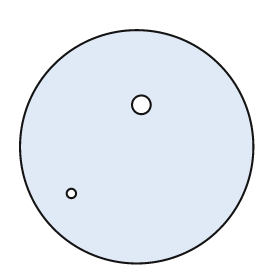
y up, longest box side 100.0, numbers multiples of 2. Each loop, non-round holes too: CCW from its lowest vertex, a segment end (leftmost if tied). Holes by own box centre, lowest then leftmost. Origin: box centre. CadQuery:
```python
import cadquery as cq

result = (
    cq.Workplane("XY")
    .moveTo(0.0, 0.0)
    .circle(50.0)
    .moveTo(-28.0, -20.0)
    .circle(2.0)
    .moveTo(2.0, 18.0)
    .circle(4.0)
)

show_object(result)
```